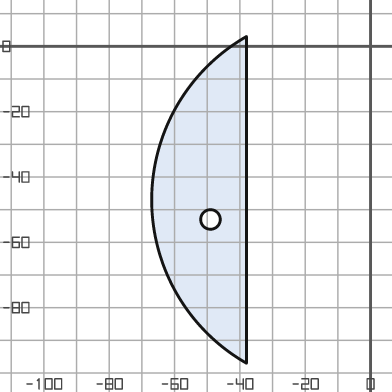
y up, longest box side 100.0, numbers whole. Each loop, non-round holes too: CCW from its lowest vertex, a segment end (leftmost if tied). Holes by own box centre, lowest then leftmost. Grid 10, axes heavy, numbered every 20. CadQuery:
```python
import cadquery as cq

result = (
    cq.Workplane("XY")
    .moveTo(-38.0, -97.0)
    .lineTo(-38.0, 3.0)
    .threePointArc((-67.0, -47.0), (-38.0, -97.0))
    .close()
    .moveTo(-49.0, -53.0)
    .circle(3.0)
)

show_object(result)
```